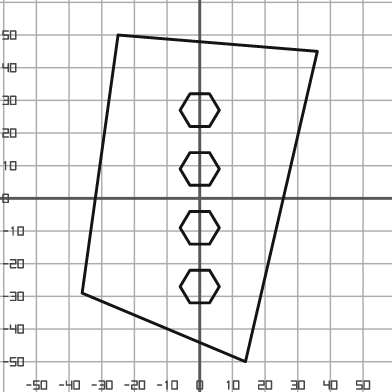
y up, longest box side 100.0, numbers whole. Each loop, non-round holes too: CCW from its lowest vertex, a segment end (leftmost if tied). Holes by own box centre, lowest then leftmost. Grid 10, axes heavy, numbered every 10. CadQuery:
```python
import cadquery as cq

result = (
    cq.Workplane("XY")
    .moveTo(14.0, -50.0)
    .lineTo(36.0, 45.0)
    .lineTo(-25.0, 50.0)
    .lineTo(-36.0, -29.0)
    .close()
    .moveTo(-3.0, -32.0)
    .lineTo(3.0, -32.0)
    .lineTo(6.0, -27.0)
    .lineTo(3.0, -22.0)
    .lineTo(-3.0, -22.0)
    .lineTo(-6.0, -27.0)
    .close()
    .moveTo(-3.0, -14.0)
    .lineTo(3.0, -14.0)
    .lineTo(6.0, -9.0)
    .lineTo(3.0, -4.0)
    .lineTo(-3.0, -4.0)
    .lineTo(-6.0, -9.0)
    .close()
    .moveTo(-3.0, 4.0)
    .lineTo(3.0, 4.0)
    .lineTo(6.0, 9.0)
    .lineTo(3.0, 14.0)
    .lineTo(-3.0, 14.0)
    .lineTo(-6.0, 9.0)
    .close()
    .moveTo(-3.0, 22.0)
    .lineTo(3.0, 22.0)
    .lineTo(6.0, 27.0)
    .lineTo(3.0, 32.0)
    .lineTo(-3.0, 32.0)
    .lineTo(-6.0, 27.0)
    .close()
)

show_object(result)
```